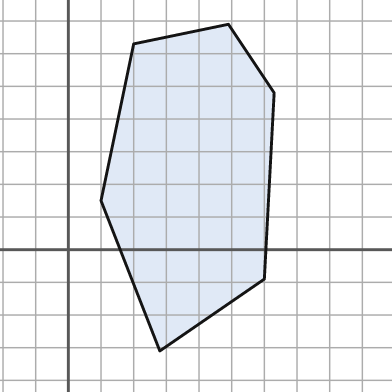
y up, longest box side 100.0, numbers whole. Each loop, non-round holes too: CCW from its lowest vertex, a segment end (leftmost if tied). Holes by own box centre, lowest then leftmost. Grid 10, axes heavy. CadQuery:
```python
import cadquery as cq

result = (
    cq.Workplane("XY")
    .moveTo(28.0, -31.0)
    .lineTo(60.0, -9.0)
    .lineTo(63.0, 48.0)
    .lineTo(49.0, 69.0)
    .lineTo(20.0, 63.0)
    .lineTo(10.0, 15.0)
    .close()
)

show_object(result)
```